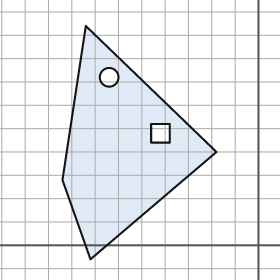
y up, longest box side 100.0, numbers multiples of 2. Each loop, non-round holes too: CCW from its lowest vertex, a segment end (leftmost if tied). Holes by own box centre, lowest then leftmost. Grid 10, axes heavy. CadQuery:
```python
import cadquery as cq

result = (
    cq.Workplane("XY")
    .moveTo(-72.0, -6.0)
    .lineTo(-18.0, 40.0)
    .lineTo(-74.0, 94.0)
    .lineTo(-84.0, 28.0)
    .close()
    .moveTo(-46.0, 44.0)
    .lineTo(-38.0, 44.0)
    .lineTo(-38.0, 52.0)
    .lineTo(-46.0, 52.0)
    .close()
    .moveTo(-64.0, 72.0)
    .circle(4.0)
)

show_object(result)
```